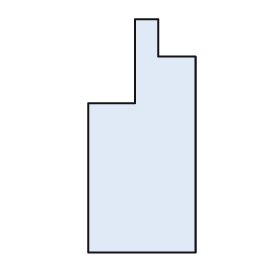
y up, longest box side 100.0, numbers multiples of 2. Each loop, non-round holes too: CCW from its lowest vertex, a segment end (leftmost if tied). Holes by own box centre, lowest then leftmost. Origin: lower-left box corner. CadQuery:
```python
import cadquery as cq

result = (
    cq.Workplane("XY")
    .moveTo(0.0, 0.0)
    .lineTo(46.0, 0.0)
    .lineTo(46.0, 84.0)
    .lineTo(30.0, 84.0)
    .lineTo(30.0, 100.0)
    .lineTo(20.0, 100.0)
    .lineTo(20.0, 64.0)
    .lineTo(0.0, 64.0)
    .close()
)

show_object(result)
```